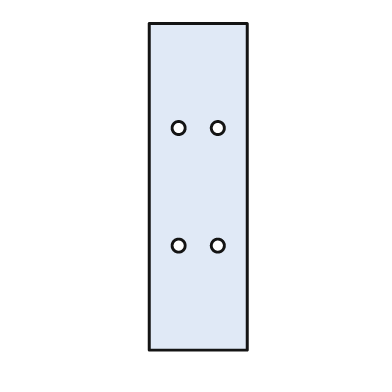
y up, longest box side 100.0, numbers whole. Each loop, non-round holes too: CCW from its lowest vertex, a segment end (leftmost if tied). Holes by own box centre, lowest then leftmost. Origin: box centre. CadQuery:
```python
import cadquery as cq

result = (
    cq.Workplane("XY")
    .moveTo(-15.0, -50.0)
    .lineTo(15.0, -50.0)
    .lineTo(15.0, 50.0)
    .lineTo(-15.0, 50.0)
    .close()
    .moveTo(-6.0, -18.0)
    .circle(2.0)
    .moveTo(6.0, -18.0)
    .circle(2.0)
    .moveTo(-6.0, 18.0)
    .circle(2.0)
    .moveTo(6.0, 18.0)
    .circle(2.0)
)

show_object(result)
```